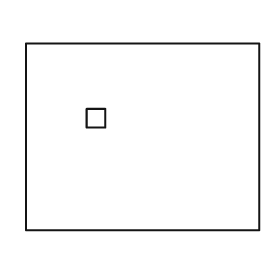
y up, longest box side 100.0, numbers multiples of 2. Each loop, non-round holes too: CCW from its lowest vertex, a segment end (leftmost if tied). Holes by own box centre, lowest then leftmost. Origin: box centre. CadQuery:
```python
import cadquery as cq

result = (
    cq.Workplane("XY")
    .moveTo(-50.0, -40.0)
    .lineTo(50.0, -40.0)
    .lineTo(50.0, 40.0)
    .lineTo(-50.0, 40.0)
    .close()
    .moveTo(-24.0, 4.0)
    .lineTo(-16.0, 4.0)
    .lineTo(-16.0, 12.0)
    .lineTo(-24.0, 12.0)
    .close()
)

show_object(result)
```